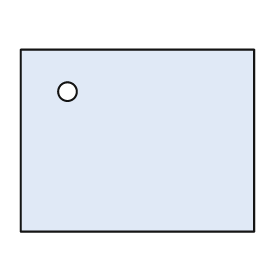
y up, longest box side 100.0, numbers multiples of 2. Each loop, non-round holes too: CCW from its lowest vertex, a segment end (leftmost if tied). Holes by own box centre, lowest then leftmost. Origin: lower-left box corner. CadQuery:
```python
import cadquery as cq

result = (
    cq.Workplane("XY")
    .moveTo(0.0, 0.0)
    .lineTo(100.0, 0.0)
    .lineTo(100.0, 78.0)
    .lineTo(0.0, 78.0)
    .close()
    .moveTo(20.0, 60.0)
    .circle(4.0)
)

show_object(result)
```